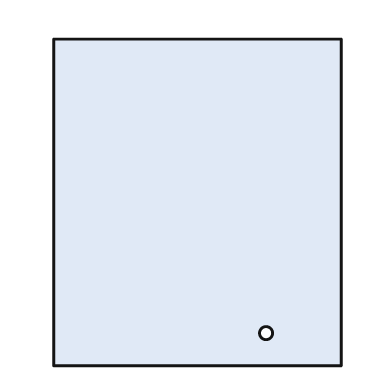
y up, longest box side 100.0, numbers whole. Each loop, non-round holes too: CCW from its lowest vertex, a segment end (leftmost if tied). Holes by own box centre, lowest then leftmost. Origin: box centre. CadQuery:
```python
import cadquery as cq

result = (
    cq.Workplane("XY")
    .moveTo(-44.0, -50.0)
    .lineTo(44.0, -50.0)
    .lineTo(44.0, 50.0)
    .lineTo(-44.0, 50.0)
    .close()
    .moveTo(21.0, -40.0)
    .circle(2.0)
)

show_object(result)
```